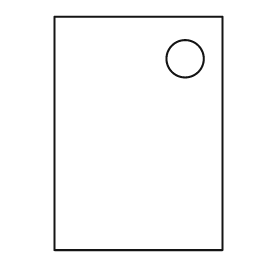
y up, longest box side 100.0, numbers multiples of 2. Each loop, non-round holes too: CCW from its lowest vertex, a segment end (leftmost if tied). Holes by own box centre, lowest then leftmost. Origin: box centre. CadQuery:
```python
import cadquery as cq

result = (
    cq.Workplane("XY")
    .moveTo(-36.0, -50.0)
    .lineTo(36.0, -50.0)
    .lineTo(36.0, 50.0)
    .lineTo(-36.0, 50.0)
    .close()
    .moveTo(20.0, 32.0)
    .circle(8.0)
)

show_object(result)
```